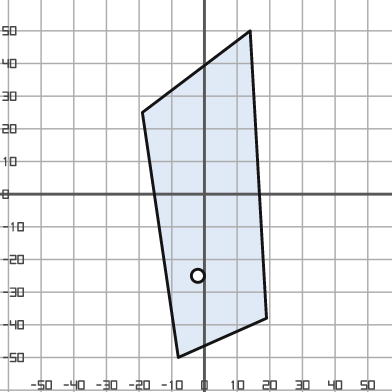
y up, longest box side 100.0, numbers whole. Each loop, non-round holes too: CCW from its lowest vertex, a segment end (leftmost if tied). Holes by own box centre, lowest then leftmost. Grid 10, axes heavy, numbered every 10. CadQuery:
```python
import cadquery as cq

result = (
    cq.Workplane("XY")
    .moveTo(-8.0, -50.0)
    .lineTo(19.0, -38.0)
    .lineTo(14.0, 50.0)
    .lineTo(-19.0, 25.0)
    .close()
    .moveTo(-2.0, -25.0)
    .circle(2.0)
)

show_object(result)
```